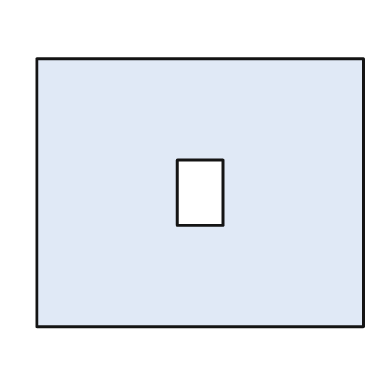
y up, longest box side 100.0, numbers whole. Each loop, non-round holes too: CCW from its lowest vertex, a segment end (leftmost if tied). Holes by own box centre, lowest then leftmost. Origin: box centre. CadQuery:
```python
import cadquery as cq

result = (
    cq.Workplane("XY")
    .moveTo(-50.0, -41.0)
    .lineTo(50.0, -41.0)
    .lineTo(50.0, 41.0)
    .lineTo(-50.0, 41.0)
    .close()
    .moveTo(-7.0, -10.0)
    .lineTo(7.0, -10.0)
    .lineTo(7.0, 10.0)
    .lineTo(-7.0, 10.0)
    .close()
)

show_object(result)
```